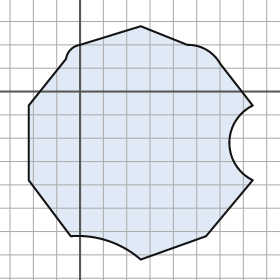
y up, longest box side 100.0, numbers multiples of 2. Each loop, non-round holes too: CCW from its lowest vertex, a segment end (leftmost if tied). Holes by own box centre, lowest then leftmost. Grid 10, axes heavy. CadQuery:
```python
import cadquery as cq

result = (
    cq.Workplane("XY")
    .moveTo(26.0, -72.0)
    .lineTo(54.0, -62.0)
    .lineTo(74.0, -38.0)
    .threePointArc((64.0, -22.0), (74.0, -6.0))
    .lineTo(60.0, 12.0)
    .threePointArc((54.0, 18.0), (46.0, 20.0))
    .lineTo(26.0, 28.0)
    .lineTo(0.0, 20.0)
    .threePointArc((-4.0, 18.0), (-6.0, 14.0))
    .lineTo(-22.0, -6.0)
    .lineTo(-22.0, -38.0)
    .lineTo(-4.0, -62.0)
    .threePointArc((12.0, -64.0), (26.0, -72.0))
    .close()
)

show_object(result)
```